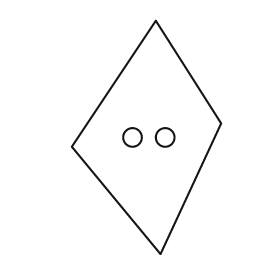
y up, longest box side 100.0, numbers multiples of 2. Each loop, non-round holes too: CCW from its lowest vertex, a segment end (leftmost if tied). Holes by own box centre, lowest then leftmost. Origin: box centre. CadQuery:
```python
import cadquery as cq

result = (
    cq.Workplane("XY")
    .moveTo(6.0, -50.0)
    .lineTo(32.0, 6.0)
    .lineTo(4.0, 50.0)
    .lineTo(-32.0, -4.0)
    .close()
    .moveTo(-6.0, 0.0)
    .circle(4.0)
    .moveTo(8.0, 0.0)
    .circle(4.0)
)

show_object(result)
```